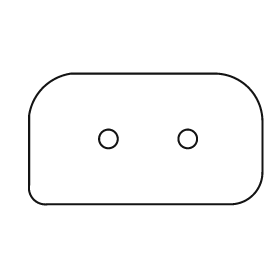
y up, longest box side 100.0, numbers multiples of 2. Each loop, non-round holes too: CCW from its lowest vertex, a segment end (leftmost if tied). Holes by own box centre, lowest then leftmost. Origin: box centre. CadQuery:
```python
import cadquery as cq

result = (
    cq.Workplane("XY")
    .moveTo(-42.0, -28.0)
    .lineTo(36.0, -28.0)
    .threePointArc((46.0, -24.0), (50.0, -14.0))
    .lineTo(50.0, 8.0)
    .threePointArc((44.0, 22.0), (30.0, 28.0))
    .lineTo(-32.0, 28.0)
    .threePointArc((-44.0, 22.0), (-50.0, 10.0))
    .lineTo(-50.0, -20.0)
    .threePointArc((-48.0, -26.0), (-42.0, -28.0))
    .close()
    .moveTo(-16.0, 0.0)
    .circle(4.0)
    .moveTo(18.0, 0.0)
    .circle(4.0)
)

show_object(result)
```